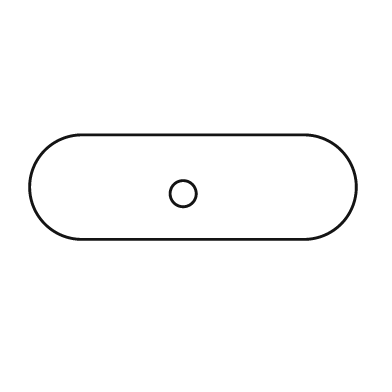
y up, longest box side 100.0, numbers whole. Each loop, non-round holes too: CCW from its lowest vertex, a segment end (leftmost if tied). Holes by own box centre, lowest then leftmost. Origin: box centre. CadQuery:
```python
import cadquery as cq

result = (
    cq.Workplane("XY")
    .moveTo(-34.0, -16.0)
    .lineTo(34.0, -16.0)
    .threePointArc((50.0, 0.0), (34.0, 16.0))
    .lineTo(-34.0, 16.0)
    .threePointArc((-50.0, 0.0), (-34.0, -16.0))
    .close()
    .moveTo(-3.0, -2.0)
    .circle(4.0)
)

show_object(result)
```